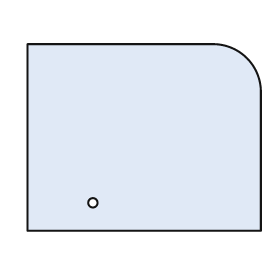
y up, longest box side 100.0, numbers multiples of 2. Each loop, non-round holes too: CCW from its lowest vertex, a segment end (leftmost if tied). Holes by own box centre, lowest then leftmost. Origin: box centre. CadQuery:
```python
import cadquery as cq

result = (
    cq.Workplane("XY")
    .moveTo(-50.0, -40.0)
    .lineTo(50.0, -40.0)
    .lineTo(50.0, 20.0)
    .threePointArc((44.0, 34.0), (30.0, 40.0))
    .lineTo(-50.0, 40.0)
    .close()
    .moveTo(-22.0, -28.0)
    .circle(2.0)
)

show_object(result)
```